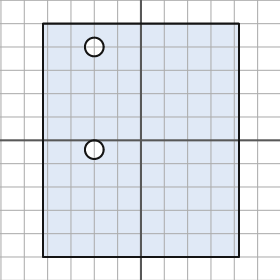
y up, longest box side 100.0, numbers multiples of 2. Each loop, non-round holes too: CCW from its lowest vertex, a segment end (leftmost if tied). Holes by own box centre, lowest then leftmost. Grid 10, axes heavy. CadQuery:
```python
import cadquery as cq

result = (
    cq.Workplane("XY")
    .moveTo(-42.0, -50.0)
    .lineTo(42.0, -50.0)
    .lineTo(42.0, 50.0)
    .lineTo(-42.0, 50.0)
    .close()
    .moveTo(-20.0, -4.0)
    .circle(4.0)
    .moveTo(-20.0, 40.0)
    .circle(4.0)
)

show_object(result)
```